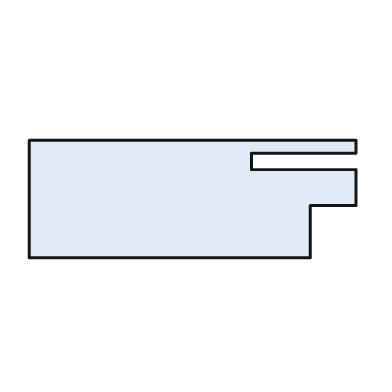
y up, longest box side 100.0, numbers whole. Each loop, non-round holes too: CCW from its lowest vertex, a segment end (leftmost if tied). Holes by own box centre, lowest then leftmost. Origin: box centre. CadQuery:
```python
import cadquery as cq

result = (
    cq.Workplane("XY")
    .moveTo(-50.0, -18.0)
    .lineTo(36.0, -18.0)
    .lineTo(36.0, -2.0)
    .lineTo(50.0, -2.0)
    .lineTo(50.0, 9.0)
    .lineTo(18.0, 9.0)
    .lineTo(18.0, 14.0)
    .lineTo(50.0, 14.0)
    .lineTo(50.0, 18.0)
    .lineTo(-50.0, 18.0)
    .close()
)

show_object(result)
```